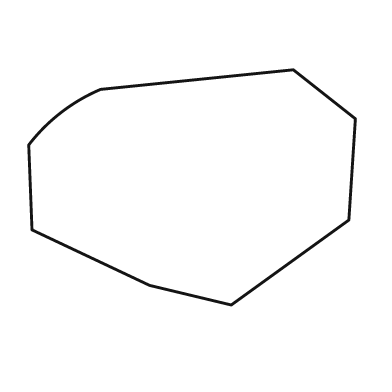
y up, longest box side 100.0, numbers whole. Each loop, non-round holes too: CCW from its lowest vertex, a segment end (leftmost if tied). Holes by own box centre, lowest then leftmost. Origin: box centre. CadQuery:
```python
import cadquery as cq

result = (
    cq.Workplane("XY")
    .moveTo(12.0, -36.0)
    .lineTo(48.0, -10.0)
    .lineTo(50.0, 21.0)
    .lineTo(31.0, 36.0)
    .lineTo(-28.0, 30.0)
    .threePointArc((-40.0, 23.0), (-50.0, 13.0))
    .lineTo(-49.0, -13.0)
    .lineTo(-13.0, -30.0)
    .close()
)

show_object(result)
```